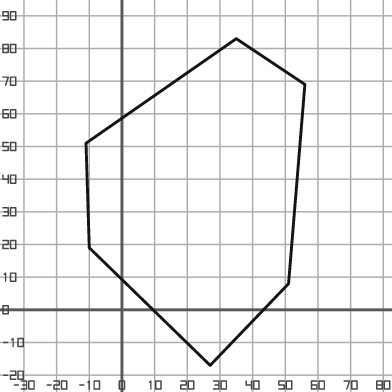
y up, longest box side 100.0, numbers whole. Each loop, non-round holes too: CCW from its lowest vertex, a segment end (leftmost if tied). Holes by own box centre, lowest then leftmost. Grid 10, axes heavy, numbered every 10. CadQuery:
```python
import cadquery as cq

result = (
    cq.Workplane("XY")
    .moveTo(27.0, -17.0)
    .lineTo(51.0, 8.0)
    .lineTo(56.0, 69.0)
    .lineTo(35.0, 83.0)
    .lineTo(-11.0, 51.0)
    .lineTo(-10.0, 19.0)
    .close()
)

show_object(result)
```